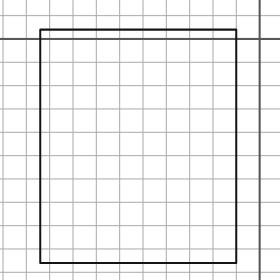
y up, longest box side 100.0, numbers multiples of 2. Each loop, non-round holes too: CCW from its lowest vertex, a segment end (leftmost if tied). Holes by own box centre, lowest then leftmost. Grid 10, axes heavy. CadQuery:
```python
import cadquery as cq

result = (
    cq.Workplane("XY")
    .moveTo(-94.0, -96.0)
    .lineTo(-10.0, -96.0)
    .lineTo(-10.0, 4.0)
    .lineTo(-94.0, 4.0)
    .close()
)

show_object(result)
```